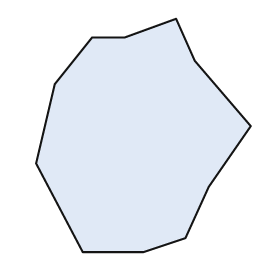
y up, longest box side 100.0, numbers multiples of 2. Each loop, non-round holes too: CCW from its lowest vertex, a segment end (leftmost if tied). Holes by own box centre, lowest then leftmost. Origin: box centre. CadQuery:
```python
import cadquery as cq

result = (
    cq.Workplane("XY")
    .moveTo(-26.0, -50.0)
    .lineTo(0.0, -50.0)
    .lineTo(18.0, -44.0)
    .lineTo(28.0, -22.0)
    .lineTo(46.0, 4.0)
    .lineTo(22.0, 32.0)
    .lineTo(14.0, 50.0)
    .lineTo(-8.0, 42.0)
    .lineTo(-22.0, 42.0)
    .lineTo(-38.0, 22.0)
    .lineTo(-46.0, -12.0)
    .close()
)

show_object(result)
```